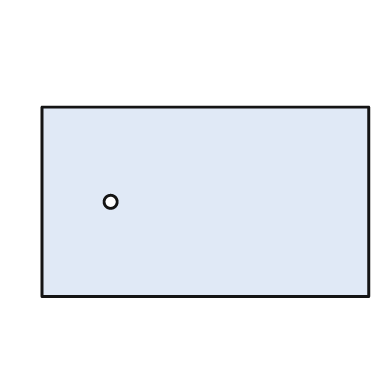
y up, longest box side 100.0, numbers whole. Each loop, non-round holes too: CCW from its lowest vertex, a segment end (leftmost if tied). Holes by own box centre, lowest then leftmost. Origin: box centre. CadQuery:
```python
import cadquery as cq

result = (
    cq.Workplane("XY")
    .moveTo(-50.0, -29.0)
    .lineTo(50.0, -29.0)
    .lineTo(50.0, 29.0)
    .lineTo(-50.0, 29.0)
    .close()
    .moveTo(-29.0, 0.0)
    .circle(2.0)
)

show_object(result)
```